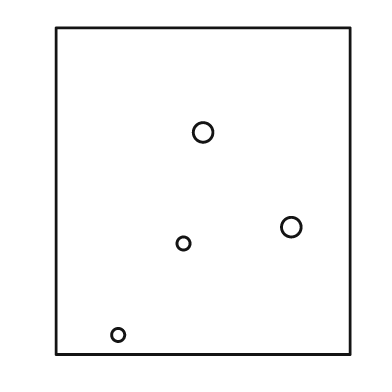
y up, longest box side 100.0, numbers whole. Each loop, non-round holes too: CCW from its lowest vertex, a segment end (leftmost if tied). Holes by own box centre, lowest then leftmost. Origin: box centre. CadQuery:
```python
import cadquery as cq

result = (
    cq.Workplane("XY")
    .moveTo(-45.0, -50.0)
    .lineTo(45.0, -50.0)
    .lineTo(45.0, 50.0)
    .lineTo(-45.0, 50.0)
    .close()
    .moveTo(-26.0, -44.0)
    .circle(2.0)
    .moveTo(-6.0, -16.0)
    .circle(2.0)
    .moveTo(27.0, -11.0)
    .circle(3.0)
    .moveTo(0.0, 18.0)
    .circle(3.0)
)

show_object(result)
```